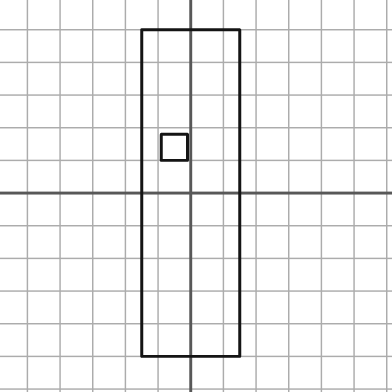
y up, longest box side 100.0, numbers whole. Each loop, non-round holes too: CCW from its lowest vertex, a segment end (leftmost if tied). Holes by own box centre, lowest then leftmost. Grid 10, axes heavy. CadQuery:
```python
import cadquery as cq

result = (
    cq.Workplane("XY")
    .moveTo(-15.0, -50.0)
    .lineTo(15.0, -50.0)
    .lineTo(15.0, 50.0)
    .lineTo(-15.0, 50.0)
    .close()
    .moveTo(-9.0, 10.0)
    .lineTo(-1.0, 10.0)
    .lineTo(-1.0, 18.0)
    .lineTo(-9.0, 18.0)
    .close()
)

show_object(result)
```